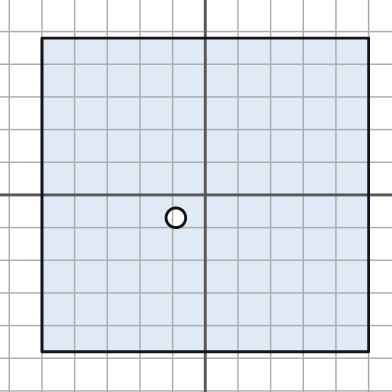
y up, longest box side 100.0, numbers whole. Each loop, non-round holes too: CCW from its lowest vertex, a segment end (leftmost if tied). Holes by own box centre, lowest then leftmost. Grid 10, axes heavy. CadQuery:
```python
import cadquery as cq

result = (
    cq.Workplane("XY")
    .moveTo(-50.0, -48.0)
    .lineTo(50.0, -48.0)
    .lineTo(50.0, 48.0)
    .lineTo(-50.0, 48.0)
    .close()
    .moveTo(-9.0, -7.0)
    .circle(3.0)
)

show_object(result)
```